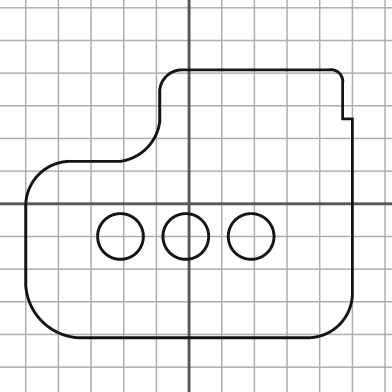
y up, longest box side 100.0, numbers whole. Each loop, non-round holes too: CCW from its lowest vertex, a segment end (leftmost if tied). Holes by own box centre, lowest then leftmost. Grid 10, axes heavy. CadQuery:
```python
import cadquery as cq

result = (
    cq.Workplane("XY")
    .moveTo(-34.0, -41.0)
    .lineTo(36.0, -41.0)
    .threePointArc((46.0, -37.0), (50.0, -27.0))
    .lineTo(50.0, 26.0)
    .lineTo(47.0, 26.0)
    .lineTo(47.0, 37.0)
    .threePointArc((46.0, 40.0), (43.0, 41.0))
    .lineTo(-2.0, 41.0)
    .threePointArc((-7.0, 39.0), (-9.0, 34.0))
    .lineTo(-9.0, 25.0)
    .threePointArc((-13.0, 17.0), (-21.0, 13.0))
    .lineTo(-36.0, 13.0)
    .threePointArc((-46.0, 9.0), (-50.0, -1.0))
    .lineTo(-50.0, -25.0)
    .threePointArc((-45.0, -36.0), (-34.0, -41.0))
    .close()
    .moveTo(-21.0, -10.0)
    .circle(7.0)
    .moveTo(-1.0, -10.0)
    .circle(7.0)
    .moveTo(19.0, -10.0)
    .circle(7.0)
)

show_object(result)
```